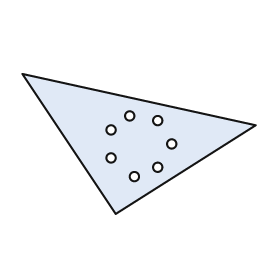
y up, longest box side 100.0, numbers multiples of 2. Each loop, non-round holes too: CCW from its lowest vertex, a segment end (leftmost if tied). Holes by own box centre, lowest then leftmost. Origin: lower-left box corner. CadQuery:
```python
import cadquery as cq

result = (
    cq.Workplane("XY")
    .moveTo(40.0, 0.0)
    .lineTo(100.0, 38.0)
    .lineTo(0.0, 60.0)
    .close()
    .moveTo(48.0, 16.0)
    .circle(2.0)
    .moveTo(58.0, 20.0)
    .circle(2.0)
    .moveTo(38.0, 24.0)
    .circle(2.0)
    .moveTo(64.0, 30.0)
    .circle(2.0)
    .moveTo(38.0, 36.0)
    .circle(2.0)
    .moveTo(58.0, 40.0)
    .circle(2.0)
    .moveTo(46.0, 42.0)
    .circle(2.0)
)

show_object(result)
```